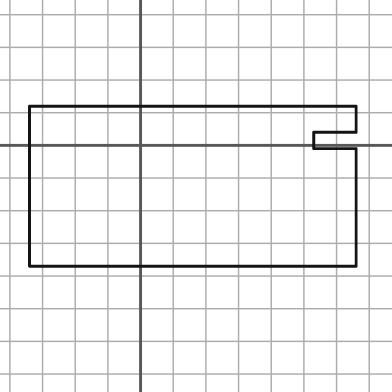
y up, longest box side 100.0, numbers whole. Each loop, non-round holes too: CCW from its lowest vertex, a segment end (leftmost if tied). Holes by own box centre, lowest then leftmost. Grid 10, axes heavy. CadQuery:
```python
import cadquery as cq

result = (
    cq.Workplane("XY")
    .moveTo(-34.0, -37.0)
    .lineTo(66.0, -37.0)
    .lineTo(66.0, -1.0)
    .lineTo(53.0, -1.0)
    .lineTo(53.0, 4.0)
    .lineTo(66.0, 4.0)
    .lineTo(66.0, 12.0)
    .lineTo(-34.0, 12.0)
    .close()
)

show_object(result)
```